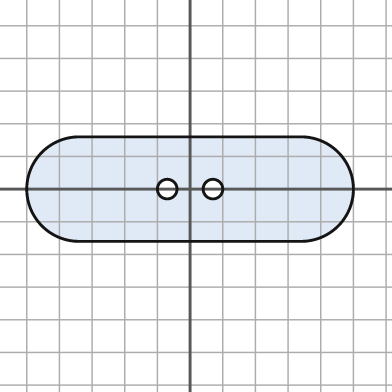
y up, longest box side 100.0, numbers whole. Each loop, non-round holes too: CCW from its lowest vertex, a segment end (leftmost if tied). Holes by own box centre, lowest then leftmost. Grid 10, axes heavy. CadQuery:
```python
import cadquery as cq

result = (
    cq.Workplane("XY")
    .moveTo(-34.0, -16.0)
    .lineTo(34.0, -16.0)
    .threePointArc((50.0, 0.0), (34.0, 16.0))
    .lineTo(-34.0, 16.0)
    .threePointArc((-50.0, 0.0), (-34.0, -16.0))
    .close()
    .moveTo(-7.0, 0.0)
    .circle(3.0)
    .moveTo(7.0, 0.0)
    .circle(3.0)
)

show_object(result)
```